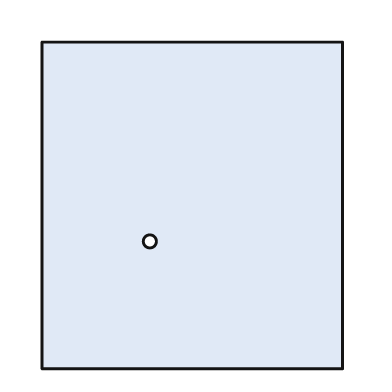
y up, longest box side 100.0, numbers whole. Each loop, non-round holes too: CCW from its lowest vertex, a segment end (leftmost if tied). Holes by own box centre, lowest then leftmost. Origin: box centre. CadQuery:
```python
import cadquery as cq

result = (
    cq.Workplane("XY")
    .moveTo(-46.0, -50.0)
    .lineTo(46.0, -50.0)
    .lineTo(46.0, 50.0)
    .lineTo(-46.0, 50.0)
    .close()
    .moveTo(-13.0, -11.0)
    .circle(2.0)
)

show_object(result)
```